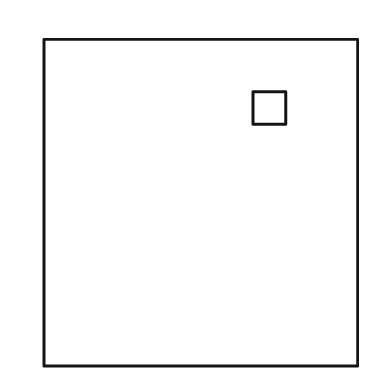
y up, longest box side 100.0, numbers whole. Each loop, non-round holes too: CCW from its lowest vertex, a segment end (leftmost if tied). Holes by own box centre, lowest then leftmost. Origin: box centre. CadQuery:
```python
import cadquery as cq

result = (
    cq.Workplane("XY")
    .moveTo(-48.0, -50.0)
    .lineTo(48.0, -50.0)
    .lineTo(48.0, 50.0)
    .lineTo(-48.0, 50.0)
    .close()
    .moveTo(16.0, 24.0)
    .lineTo(26.0, 24.0)
    .lineTo(26.0, 34.0)
    .lineTo(16.0, 34.0)
    .close()
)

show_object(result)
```